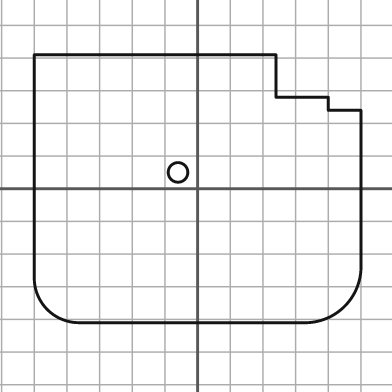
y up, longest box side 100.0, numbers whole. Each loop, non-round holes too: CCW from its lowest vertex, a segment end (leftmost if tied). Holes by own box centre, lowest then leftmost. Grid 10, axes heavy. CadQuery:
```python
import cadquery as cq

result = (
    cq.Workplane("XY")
    .moveTo(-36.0, -41.0)
    .lineTo(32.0, -41.0)
    .threePointArc((45.0, -36.0), (50.0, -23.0))
    .lineTo(50.0, 24.0)
    .lineTo(40.0, 24.0)
    .lineTo(40.0, 28.0)
    .lineTo(24.0, 28.0)
    .lineTo(24.0, 41.0)
    .lineTo(-50.0, 41.0)
    .lineTo(-50.0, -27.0)
    .threePointArc((-46.0, -37.0), (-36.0, -41.0))
    .close()
    .moveTo(-6.0, 5.0)
    .circle(3.0)
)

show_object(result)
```